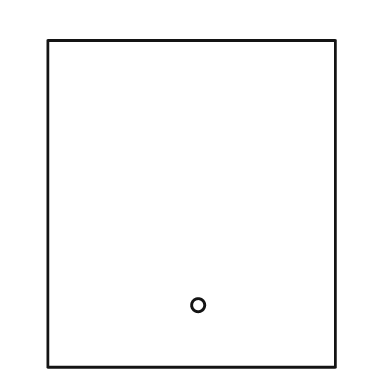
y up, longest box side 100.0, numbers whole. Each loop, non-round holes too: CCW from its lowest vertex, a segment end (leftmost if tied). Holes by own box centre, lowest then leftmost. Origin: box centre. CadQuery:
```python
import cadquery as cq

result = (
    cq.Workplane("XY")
    .moveTo(-44.0, -50.0)
    .lineTo(44.0, -50.0)
    .lineTo(44.0, 50.0)
    .lineTo(-44.0, 50.0)
    .close()
    .moveTo(2.0, -31.0)
    .circle(2.0)
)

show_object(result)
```